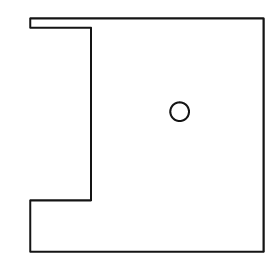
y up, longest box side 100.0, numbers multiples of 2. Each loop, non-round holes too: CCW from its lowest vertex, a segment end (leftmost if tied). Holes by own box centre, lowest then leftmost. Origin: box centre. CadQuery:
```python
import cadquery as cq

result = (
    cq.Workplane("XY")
    .moveTo(-50.0, -50.0)
    .lineTo(50.0, -50.0)
    .lineTo(50.0, 50.0)
    .lineTo(-50.0, 50.0)
    .lineTo(-50.0, 46.0)
    .lineTo(-24.0, 46.0)
    .lineTo(-24.0, -28.0)
    .lineTo(-50.0, -28.0)
    .close()
    .moveTo(14.0, 10.0)
    .circle(4.0)
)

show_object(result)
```